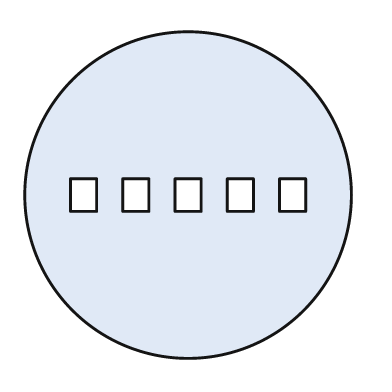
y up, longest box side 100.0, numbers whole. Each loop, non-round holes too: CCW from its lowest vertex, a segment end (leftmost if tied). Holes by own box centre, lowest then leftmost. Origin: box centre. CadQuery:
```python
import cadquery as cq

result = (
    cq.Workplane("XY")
    .moveTo(0.0, 0.0)
    .circle(50.0)
    .moveTo(-36.0, -5.0)
    .lineTo(-28.0, -5.0)
    .lineTo(-28.0, 5.0)
    .lineTo(-36.0, 5.0)
    .close()
    .moveTo(-20.0, -5.0)
    .lineTo(-12.0, -5.0)
    .lineTo(-12.0, 5.0)
    .lineTo(-20.0, 5.0)
    .close()
    .moveTo(-4.0, -5.0)
    .lineTo(4.0, -5.0)
    .lineTo(4.0, 5.0)
    .lineTo(-4.0, 5.0)
    .close()
    .moveTo(12.0, -5.0)
    .lineTo(20.0, -5.0)
    .lineTo(20.0, 5.0)
    .lineTo(12.0, 5.0)
    .close()
    .moveTo(28.0, -5.0)
    .lineTo(36.0, -5.0)
    .lineTo(36.0, 5.0)
    .lineTo(28.0, 5.0)
    .close()
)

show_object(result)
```